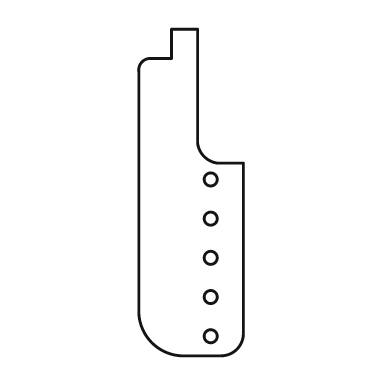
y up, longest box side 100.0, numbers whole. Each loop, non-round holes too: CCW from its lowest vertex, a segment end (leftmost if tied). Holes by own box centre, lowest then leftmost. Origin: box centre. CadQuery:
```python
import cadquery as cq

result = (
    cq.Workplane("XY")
    .moveTo(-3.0, -50.0)
    .lineTo(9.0, -50.0)
    .threePointArc((14.0, -48.0), (16.0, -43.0))
    .lineTo(16.0, 9.0)
    .lineTo(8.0, 9.0)
    .threePointArc((4.0, 11.0), (2.0, 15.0))
    .lineTo(2.0, 50.0)
    .lineTo(-6.0, 50.0)
    .lineTo(-6.0, 41.0)
    .lineTo(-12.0, 41.0)
    .threePointArc((-15.0, 40.0), (-16.0, 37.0))
    .lineTo(-16.0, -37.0)
    .threePointArc((-12.0, -46.0), (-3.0, -50.0))
    .close()
    .moveTo(6.0, -44.0)
    .circle(2.0)
    .moveTo(6.0, -32.0)
    .circle(2.0)
    .moveTo(6.0, -20.0)
    .circle(2.0)
    .moveTo(6.0, -8.0)
    .circle(2.0)
    .moveTo(6.0, 4.0)
    .circle(2.0)
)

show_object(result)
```